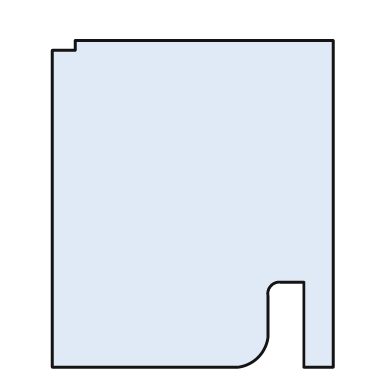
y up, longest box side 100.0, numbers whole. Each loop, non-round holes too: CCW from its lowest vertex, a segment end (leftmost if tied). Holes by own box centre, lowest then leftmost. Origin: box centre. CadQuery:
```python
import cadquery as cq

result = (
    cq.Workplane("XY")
    .moveTo(-43.0, -50.0)
    .lineTo(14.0, -50.0)
    .threePointArc((20.0, -47.0), (23.0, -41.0))
    .lineTo(23.0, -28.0)
    .threePointArc((24.0, -25.0), (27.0, -24.0))
    .lineTo(34.0, -24.0)
    .lineTo(34.0, -50.0)
    .lineTo(43.0, -50.0)
    .lineTo(43.0, 50.0)
    .lineTo(-36.0, 50.0)
    .lineTo(-36.0, 47.0)
    .lineTo(-43.0, 47.0)
    .close()
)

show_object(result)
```